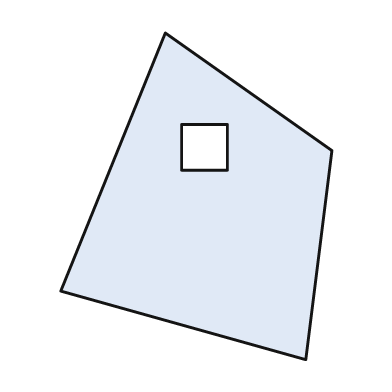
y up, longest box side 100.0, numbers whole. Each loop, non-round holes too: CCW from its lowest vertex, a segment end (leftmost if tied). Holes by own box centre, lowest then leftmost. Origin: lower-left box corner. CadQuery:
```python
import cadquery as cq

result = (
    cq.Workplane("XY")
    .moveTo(75.0, 0.0)
    .lineTo(83.0, 64.0)
    .lineTo(32.0, 100.0)
    .lineTo(0.0, 21.0)
    .close()
    .moveTo(37.0, 58.0)
    .lineTo(51.0, 58.0)
    .lineTo(51.0, 72.0)
    .lineTo(37.0, 72.0)
    .close()
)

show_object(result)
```